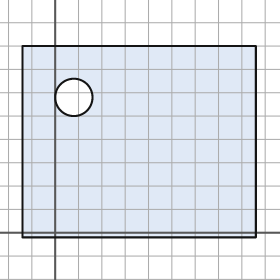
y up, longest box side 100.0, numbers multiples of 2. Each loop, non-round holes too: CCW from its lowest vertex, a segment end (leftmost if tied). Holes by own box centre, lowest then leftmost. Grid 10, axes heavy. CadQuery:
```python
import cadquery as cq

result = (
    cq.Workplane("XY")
    .moveTo(-14.0, -2.0)
    .lineTo(86.0, -2.0)
    .lineTo(86.0, 80.0)
    .lineTo(-14.0, 80.0)
    .close()
    .moveTo(8.0, 58.0)
    .circle(8.0)
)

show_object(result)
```